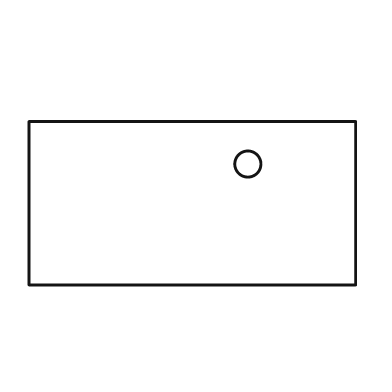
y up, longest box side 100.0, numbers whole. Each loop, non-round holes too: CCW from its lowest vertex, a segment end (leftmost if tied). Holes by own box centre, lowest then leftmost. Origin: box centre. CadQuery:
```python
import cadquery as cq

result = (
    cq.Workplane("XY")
    .moveTo(-50.0, -25.0)
    .lineTo(50.0, -25.0)
    .lineTo(50.0, 25.0)
    .lineTo(-50.0, 25.0)
    .close()
    .moveTo(17.0, 12.0)
    .circle(4.0)
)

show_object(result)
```